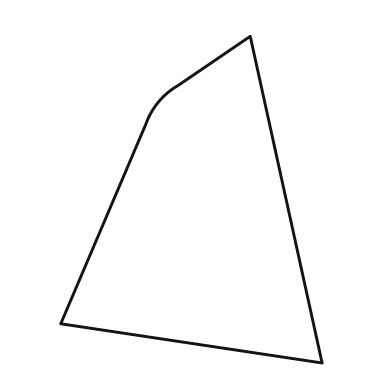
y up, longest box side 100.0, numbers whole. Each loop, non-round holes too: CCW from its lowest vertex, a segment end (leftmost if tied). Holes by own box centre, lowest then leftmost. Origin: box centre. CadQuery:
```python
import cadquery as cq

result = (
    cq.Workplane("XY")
    .moveTo(40.0, -50.0)
    .lineTo(18.0, 50.0)
    .lineTo(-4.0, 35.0)
    .threePointArc((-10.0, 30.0), (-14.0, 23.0))
    .lineTo(-40.0, -38.0)
    .close()
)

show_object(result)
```